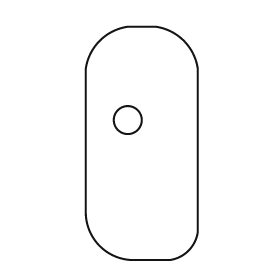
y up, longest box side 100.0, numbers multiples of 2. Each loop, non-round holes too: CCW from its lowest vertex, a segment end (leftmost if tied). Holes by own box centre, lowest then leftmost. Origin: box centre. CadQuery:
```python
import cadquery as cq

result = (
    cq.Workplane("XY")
    .moveTo(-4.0, -50.0)
    .lineTo(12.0, -50.0)
    .threePointArc((20.0, -46.0), (24.0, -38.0))
    .lineTo(24.0, 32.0)
    .threePointArc((18.0, 44.0), (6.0, 50.0))
    .lineTo(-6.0, 50.0)
    .threePointArc((-18.0, 44.0), (-24.0, 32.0))
    .lineTo(-24.0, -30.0)
    .threePointArc((-18.0, -44.0), (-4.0, -50.0))
    .close()
    .moveTo(-6.0, 10.0)
    .circle(6.0)
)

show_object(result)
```